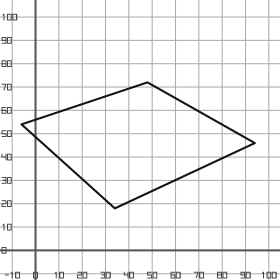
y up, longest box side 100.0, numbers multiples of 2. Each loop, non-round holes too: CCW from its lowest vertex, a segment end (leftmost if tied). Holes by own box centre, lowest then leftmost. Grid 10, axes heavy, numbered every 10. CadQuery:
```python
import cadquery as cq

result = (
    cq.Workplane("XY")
    .moveTo(34.0, 18.0)
    .lineTo(94.0, 46.0)
    .lineTo(48.0, 72.0)
    .lineTo(-6.0, 54.0)
    .close()
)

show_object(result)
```